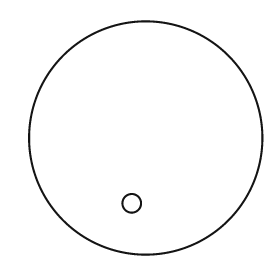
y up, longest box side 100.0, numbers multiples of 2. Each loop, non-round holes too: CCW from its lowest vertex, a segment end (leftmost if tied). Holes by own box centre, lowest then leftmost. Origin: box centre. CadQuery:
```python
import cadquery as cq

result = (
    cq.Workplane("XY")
    .moveTo(0.0, 0.0)
    .circle(50.0)
    .moveTo(-6.0, -28.0)
    .circle(4.0)
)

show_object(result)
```